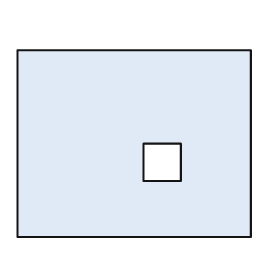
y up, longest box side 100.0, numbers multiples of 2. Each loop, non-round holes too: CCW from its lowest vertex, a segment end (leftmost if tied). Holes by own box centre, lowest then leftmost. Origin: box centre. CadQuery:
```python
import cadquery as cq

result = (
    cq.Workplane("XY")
    .moveTo(-50.0, -40.0)
    .lineTo(50.0, -40.0)
    .lineTo(50.0, 40.0)
    .lineTo(-50.0, 40.0)
    .close()
    .moveTo(4.0, -16.0)
    .lineTo(20.0, -16.0)
    .lineTo(20.0, 0.0)
    .lineTo(4.0, 0.0)
    .close()
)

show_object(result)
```